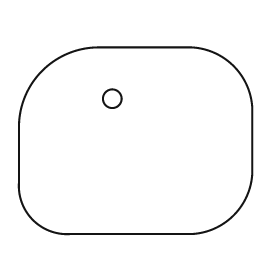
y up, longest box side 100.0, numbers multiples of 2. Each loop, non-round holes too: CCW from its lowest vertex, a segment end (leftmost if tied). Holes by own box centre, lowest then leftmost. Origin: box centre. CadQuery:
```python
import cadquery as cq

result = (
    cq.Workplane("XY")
    .moveTo(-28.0, -40.0)
    .lineTo(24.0, -40.0)
    .threePointArc((42.0, -32.0), (50.0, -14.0))
    .lineTo(50.0, 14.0)
    .threePointArc((42.0, 32.0), (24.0, 40.0))
    .lineTo(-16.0, 40.0)
    .threePointArc((-40.0, 30.0), (-50.0, 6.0))
    .lineTo(-50.0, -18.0)
    .threePointArc((-44.0, -34.0), (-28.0, -40.0))
    .close()
    .moveTo(-10.0, 18.0)
    .circle(4.0)
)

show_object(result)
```